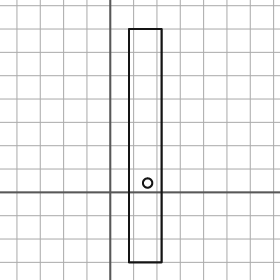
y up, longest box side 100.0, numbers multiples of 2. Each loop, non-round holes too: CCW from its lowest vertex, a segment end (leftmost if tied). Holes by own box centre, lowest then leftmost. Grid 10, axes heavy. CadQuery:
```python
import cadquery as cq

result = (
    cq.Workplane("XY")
    .moveTo(8.0, -30.0)
    .lineTo(22.0, -30.0)
    .lineTo(22.0, 70.0)
    .lineTo(8.0, 70.0)
    .close()
    .moveTo(16.0, 4.0)
    .circle(2.0)
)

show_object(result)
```